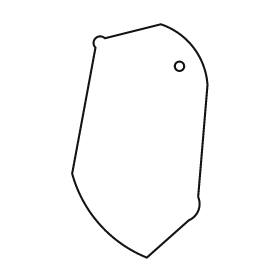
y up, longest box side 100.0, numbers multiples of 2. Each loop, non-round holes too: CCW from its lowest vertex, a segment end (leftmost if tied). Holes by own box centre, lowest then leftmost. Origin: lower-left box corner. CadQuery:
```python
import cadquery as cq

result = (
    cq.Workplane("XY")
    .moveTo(32.0, 0.0)
    .lineTo(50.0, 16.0)
    .threePointArc((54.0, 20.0), (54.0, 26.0))
    .lineTo(58.0, 74.0)
    .threePointArc((52.0, 90.0), (38.0, 100.0))
    .lineTo(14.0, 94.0)
    .threePointArc((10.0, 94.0), (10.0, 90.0))
    .lineTo(0.0, 36.0)
    .threePointArc((12.0, 14.0), (32.0, 0.0))
    .close()
    .moveTo(46.0, 82.0)
    .circle(2.0)
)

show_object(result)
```